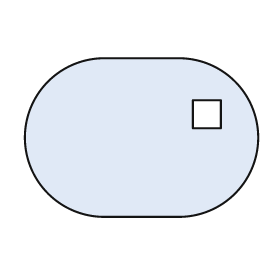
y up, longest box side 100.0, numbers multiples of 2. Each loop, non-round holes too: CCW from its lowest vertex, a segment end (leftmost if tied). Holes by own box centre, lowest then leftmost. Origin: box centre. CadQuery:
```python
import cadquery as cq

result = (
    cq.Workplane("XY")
    .moveTo(-16.0, -34.0)
    .lineTo(16.0, -34.0)
    .threePointArc((50.0, 0.0), (16.0, 34.0))
    .lineTo(-16.0, 34.0)
    .threePointArc((-50.0, 0.0), (-16.0, -34.0))
    .close()
    .moveTo(22.0, 4.0)
    .lineTo(34.0, 4.0)
    .lineTo(34.0, 16.0)
    .lineTo(22.0, 16.0)
    .close()
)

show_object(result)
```